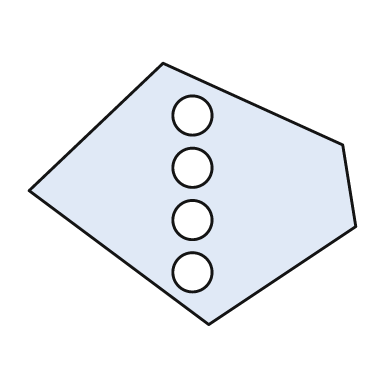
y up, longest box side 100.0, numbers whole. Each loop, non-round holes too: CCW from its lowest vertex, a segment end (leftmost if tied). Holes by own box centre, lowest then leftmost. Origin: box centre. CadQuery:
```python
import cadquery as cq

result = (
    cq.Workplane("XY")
    .moveTo(5.0, -40.0)
    .lineTo(50.0, -10.0)
    .lineTo(46.0, 15.0)
    .lineTo(-9.0, 40.0)
    .lineTo(-50.0, 1.0)
    .close()
    .moveTo(0.0, -24.0)
    .circle(6.0)
    .moveTo(0.0, -8.0)
    .circle(6.0)
    .moveTo(0.0, 8.0)
    .circle(6.0)
    .moveTo(0.0, 24.0)
    .circle(6.0)
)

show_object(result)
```